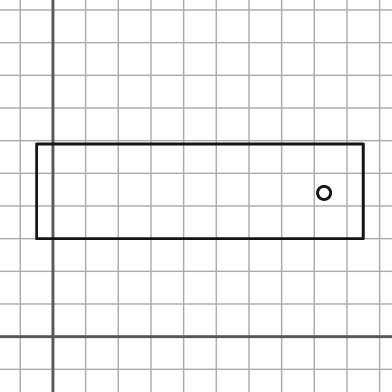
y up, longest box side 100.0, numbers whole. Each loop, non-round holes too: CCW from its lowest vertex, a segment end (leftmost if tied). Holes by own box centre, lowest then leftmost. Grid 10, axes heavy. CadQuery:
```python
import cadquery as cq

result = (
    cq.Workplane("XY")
    .moveTo(-5.0, 30.0)
    .lineTo(95.0, 30.0)
    .lineTo(95.0, 59.0)
    .lineTo(-5.0, 59.0)
    .close()
    .moveTo(83.0, 44.0)
    .circle(2.0)
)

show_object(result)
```